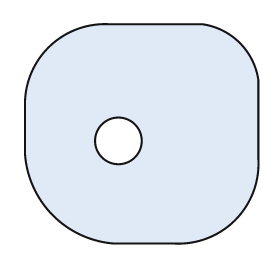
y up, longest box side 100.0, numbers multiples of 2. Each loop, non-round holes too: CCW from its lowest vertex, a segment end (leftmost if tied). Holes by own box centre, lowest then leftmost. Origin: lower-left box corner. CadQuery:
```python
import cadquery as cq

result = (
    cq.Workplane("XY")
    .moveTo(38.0, 0.0)
    .lineTo(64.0, 0.0)
    .threePointArc((90.0, 10.0), (100.0, 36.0))
    .lineTo(100.0, 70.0)
    .threePointArc((92.0, 86.0), (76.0, 94.0))
    .lineTo(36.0, 94.0)
    .threePointArc((10.0, 84.0), (0.0, 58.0))
    .lineTo(0.0, 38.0)
    .threePointArc((12.0, 12.0), (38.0, 0.0))
    .close()
    .moveTo(40.0, 44.0)
    .circle(10.0)
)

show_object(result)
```